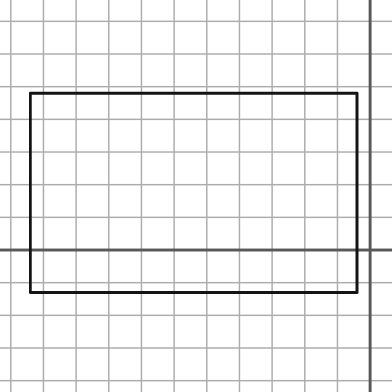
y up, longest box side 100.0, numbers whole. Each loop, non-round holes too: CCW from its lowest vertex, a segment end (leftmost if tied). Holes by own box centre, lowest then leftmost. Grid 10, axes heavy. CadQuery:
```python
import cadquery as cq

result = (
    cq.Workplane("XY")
    .moveTo(-104.0, -13.0)
    .lineTo(-4.0, -13.0)
    .lineTo(-4.0, 48.0)
    .lineTo(-104.0, 48.0)
    .close()
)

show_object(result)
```